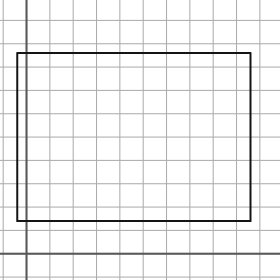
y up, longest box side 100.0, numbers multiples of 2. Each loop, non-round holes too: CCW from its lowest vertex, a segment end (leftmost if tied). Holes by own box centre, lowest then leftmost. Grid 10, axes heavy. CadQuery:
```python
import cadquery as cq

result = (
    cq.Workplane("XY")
    .moveTo(-4.0, 14.0)
    .lineTo(96.0, 14.0)
    .lineTo(96.0, 86.0)
    .lineTo(-4.0, 86.0)
    .close()
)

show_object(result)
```